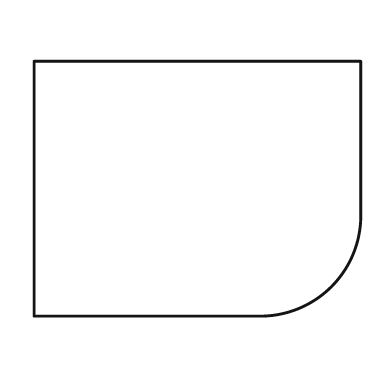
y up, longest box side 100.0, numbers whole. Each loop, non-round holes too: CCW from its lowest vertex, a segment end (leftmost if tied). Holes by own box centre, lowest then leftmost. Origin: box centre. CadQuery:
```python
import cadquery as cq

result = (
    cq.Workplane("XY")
    .moveTo(-50.0, -39.0)
    .lineTo(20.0, -39.0)
    .threePointArc((41.0, -30.0), (50.0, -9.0))
    .lineTo(50.0, 39.0)
    .lineTo(-50.0, 39.0)
    .close()
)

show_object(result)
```